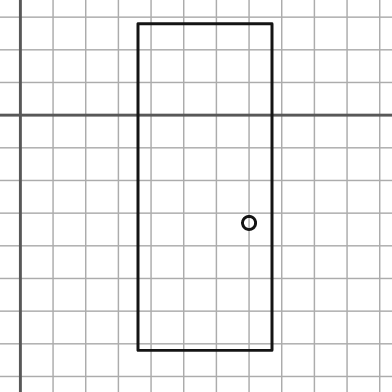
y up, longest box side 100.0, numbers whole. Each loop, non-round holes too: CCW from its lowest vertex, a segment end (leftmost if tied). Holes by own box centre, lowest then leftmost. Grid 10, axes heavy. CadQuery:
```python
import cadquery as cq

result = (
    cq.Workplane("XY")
    .moveTo(36.0, -72.0)
    .lineTo(77.0, -72.0)
    .lineTo(77.0, 28.0)
    .lineTo(36.0, 28.0)
    .close()
    .moveTo(70.0, -33.0)
    .circle(2.0)
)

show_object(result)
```